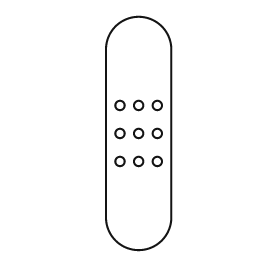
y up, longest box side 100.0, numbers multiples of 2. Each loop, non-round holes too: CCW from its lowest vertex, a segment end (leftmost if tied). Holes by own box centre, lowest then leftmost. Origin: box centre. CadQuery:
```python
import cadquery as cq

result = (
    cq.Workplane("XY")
    .moveTo(-14.0, -36.0)
    .threePointArc((0.0, -50.0), (14.0, -36.0))
    .lineTo(14.0, 36.0)
    .threePointArc((0.0, 50.0), (-14.0, 36.0))
    .close()
    .moveTo(-8.0, -12.0)
    .circle(2.0)
    .moveTo(0.0, -12.0)
    .circle(2.0)
    .moveTo(8.0, -12.0)
    .circle(2.0)
    .moveTo(-8.0, 0.0)
    .circle(2.0)
    .moveTo(0.0, 0.0)
    .circle(2.0)
    .moveTo(8.0, 0.0)
    .circle(2.0)
    .moveTo(-8.0, 12.0)
    .circle(2.0)
    .moveTo(0.0, 12.0)
    .circle(2.0)
    .moveTo(8.0, 12.0)
    .circle(2.0)
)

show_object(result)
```